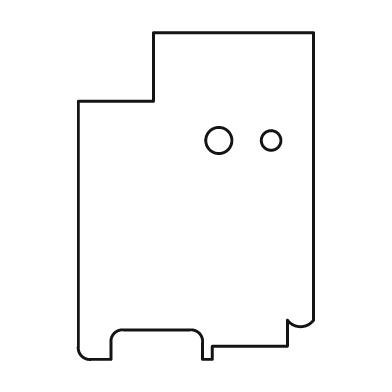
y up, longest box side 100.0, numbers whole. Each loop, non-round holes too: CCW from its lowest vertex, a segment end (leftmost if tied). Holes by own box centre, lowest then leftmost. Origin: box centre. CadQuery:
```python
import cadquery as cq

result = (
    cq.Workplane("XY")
    .moveTo(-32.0, -50.0)
    .lineTo(-26.0, -50.0)
    .lineTo(-26.0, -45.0)
    .threePointArc((-25.0, -42.0), (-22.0, -41.0))
    .lineTo(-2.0, -41.0)
    .threePointArc((1.0, -42.0), (2.0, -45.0))
    .lineTo(2.0, -50.0)
    .lineTo(5.0, -50.0)
    .lineTo(5.0, -46.0)
    .lineTo(28.0, -46.0)
    .lineTo(28.0, -38.0)
    .threePointArc((32.0, -40.0), (36.0, -38.0))
    .lineTo(36.0, 50.0)
    .lineTo(-13.0, 50.0)
    .lineTo(-13.0, 29.0)
    .lineTo(-36.0, 29.0)
    .lineTo(-36.0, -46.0)
    .threePointArc((-35.0, -49.0), (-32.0, -50.0))
    .close()
    .moveTo(7.0, 17.0)
    .circle(4.0)
    .moveTo(23.0, 17.0)
    .circle(3.0)
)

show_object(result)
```